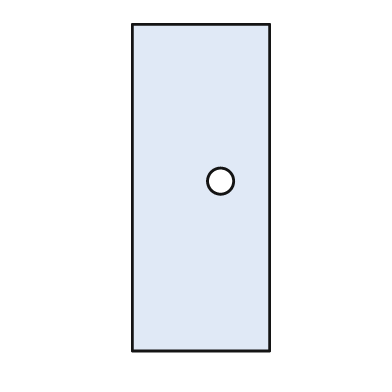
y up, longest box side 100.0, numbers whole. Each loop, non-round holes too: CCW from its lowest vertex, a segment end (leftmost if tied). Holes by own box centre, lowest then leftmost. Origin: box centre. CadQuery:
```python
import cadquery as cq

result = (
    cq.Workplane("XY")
    .moveTo(-21.0, -50.0)
    .lineTo(21.0, -50.0)
    .lineTo(21.0, 50.0)
    .lineTo(-21.0, 50.0)
    .close()
    .moveTo(6.0, 2.0)
    .circle(4.0)
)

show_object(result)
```